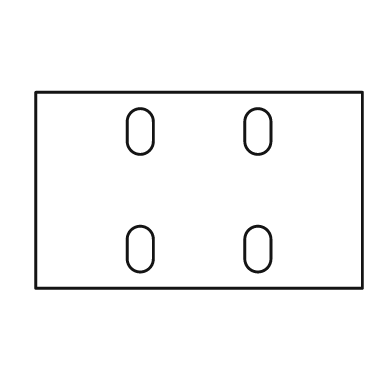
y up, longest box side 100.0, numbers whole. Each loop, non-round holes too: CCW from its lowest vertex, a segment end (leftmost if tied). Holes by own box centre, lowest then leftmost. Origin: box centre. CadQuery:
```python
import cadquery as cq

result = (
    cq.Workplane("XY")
    .moveTo(-50.0, -30.0)
    .lineTo(50.0, -30.0)
    .lineTo(50.0, 30.0)
    .lineTo(-50.0, 30.0)
    .close()
    .moveTo(-22.0, -21.0)
    .threePointArc((-18.0, -25.0), (-14.0, -21.0))
    .lineTo(-14.0, -15.0)
    .threePointArc((-18.0, -11.0), (-22.0, -15.0))
    .close()
    .moveTo(14.0, -21.0)
    .threePointArc((18.0, -25.0), (22.0, -21.0))
    .lineTo(22.0, -15.0)
    .threePointArc((18.0, -11.0), (14.0, -15.0))
    .close()
    .moveTo(-22.0, 15.0)
    .threePointArc((-18.0, 11.0), (-14.0, 15.0))
    .lineTo(-14.0, 21.0)
    .threePointArc((-18.0, 25.0), (-22.0, 21.0))
    .close()
    .moveTo(14.0, 15.0)
    .threePointArc((18.0, 11.0), (22.0, 15.0))
    .lineTo(22.0, 21.0)
    .threePointArc((18.0, 25.0), (14.0, 21.0))
    .close()
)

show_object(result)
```